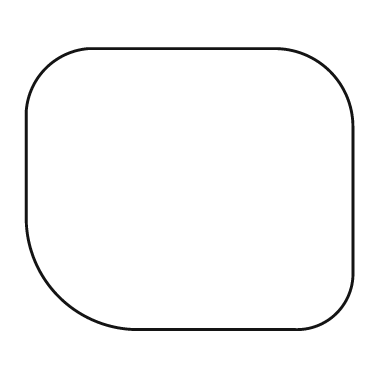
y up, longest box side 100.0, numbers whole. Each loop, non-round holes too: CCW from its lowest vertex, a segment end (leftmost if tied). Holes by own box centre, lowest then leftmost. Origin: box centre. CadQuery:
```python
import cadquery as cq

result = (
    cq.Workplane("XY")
    .moveTo(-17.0, -43.0)
    .lineTo(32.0, -43.0)
    .threePointArc((45.0, -38.0), (50.0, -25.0))
    .lineTo(50.0, 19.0)
    .threePointArc((43.0, 36.0), (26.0, 43.0))
    .lineTo(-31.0, 43.0)
    .threePointArc((-44.0, 37.0), (-50.0, 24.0))
    .lineTo(-50.0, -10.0)
    .threePointArc((-40.0, -33.0), (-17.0, -43.0))
    .close()
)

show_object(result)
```